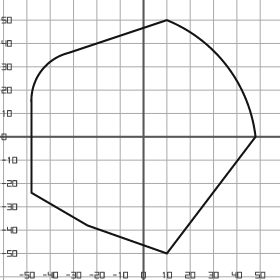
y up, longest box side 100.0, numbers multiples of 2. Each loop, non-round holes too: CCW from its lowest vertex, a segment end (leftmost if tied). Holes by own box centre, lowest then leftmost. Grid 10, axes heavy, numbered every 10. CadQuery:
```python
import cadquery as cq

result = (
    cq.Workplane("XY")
    .moveTo(10.0, -50.0)
    .lineTo(48.0, 0.0)
    .threePointArc((36.0, 30.0), (10.0, 50.0))
    .lineTo(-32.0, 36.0)
    .threePointArc((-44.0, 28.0), (-48.0, 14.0))
    .lineTo(-48.0, -24.0)
    .lineTo(-24.0, -38.0)
    .close()
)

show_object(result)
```